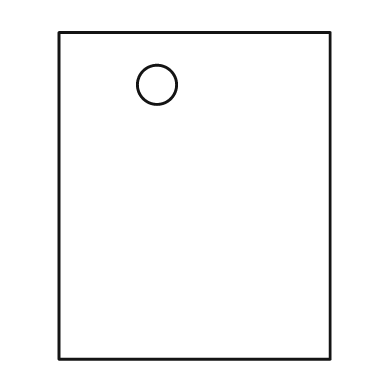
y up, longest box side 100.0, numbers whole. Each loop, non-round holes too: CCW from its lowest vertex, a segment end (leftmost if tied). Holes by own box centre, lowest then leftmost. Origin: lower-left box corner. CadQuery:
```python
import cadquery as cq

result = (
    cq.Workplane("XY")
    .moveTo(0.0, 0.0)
    .lineTo(83.0, 0.0)
    .lineTo(83.0, 100.0)
    .lineTo(0.0, 100.0)
    .close()
    .moveTo(30.0, 84.0)
    .circle(6.0)
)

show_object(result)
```